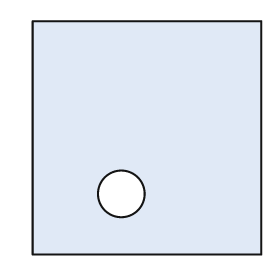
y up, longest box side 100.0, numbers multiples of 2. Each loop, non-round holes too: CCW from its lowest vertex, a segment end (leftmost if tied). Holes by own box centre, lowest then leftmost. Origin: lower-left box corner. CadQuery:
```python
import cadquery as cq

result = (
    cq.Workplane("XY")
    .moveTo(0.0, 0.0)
    .lineTo(98.0, 0.0)
    .lineTo(98.0, 100.0)
    .lineTo(0.0, 100.0)
    .close()
    .moveTo(38.0, 26.0)
    .circle(10.0)
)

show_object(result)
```